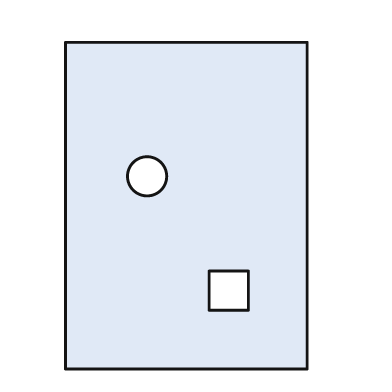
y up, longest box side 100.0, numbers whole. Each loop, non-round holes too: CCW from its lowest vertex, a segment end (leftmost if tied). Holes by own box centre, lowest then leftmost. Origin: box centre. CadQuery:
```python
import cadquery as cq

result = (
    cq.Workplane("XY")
    .moveTo(-37.0, -50.0)
    .lineTo(37.0, -50.0)
    .lineTo(37.0, 50.0)
    .lineTo(-37.0, 50.0)
    .close()
    .moveTo(7.0, -32.0)
    .lineTo(19.0, -32.0)
    .lineTo(19.0, -20.0)
    .lineTo(7.0, -20.0)
    .close()
    .moveTo(-12.0, 9.0)
    .circle(6.0)
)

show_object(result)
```